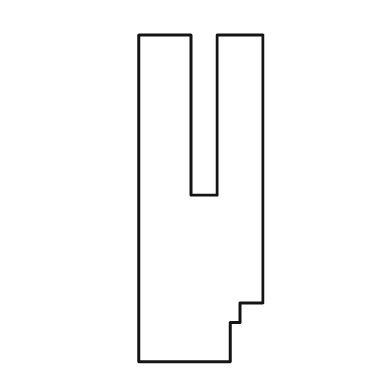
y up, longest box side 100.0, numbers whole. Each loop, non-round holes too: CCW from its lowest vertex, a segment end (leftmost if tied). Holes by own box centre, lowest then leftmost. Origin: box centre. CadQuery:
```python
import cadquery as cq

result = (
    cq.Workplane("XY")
    .moveTo(-19.0, -50.0)
    .lineTo(9.0, -50.0)
    .lineTo(9.0, -38.0)
    .lineTo(12.0, -38.0)
    .lineTo(12.0, -32.0)
    .lineTo(19.0, -32.0)
    .lineTo(19.0, 50.0)
    .lineTo(5.0, 50.0)
    .lineTo(5.0, 1.0)
    .lineTo(-3.0, 1.0)
    .lineTo(-3.0, 50.0)
    .lineTo(-19.0, 50.0)
    .close()
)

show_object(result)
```